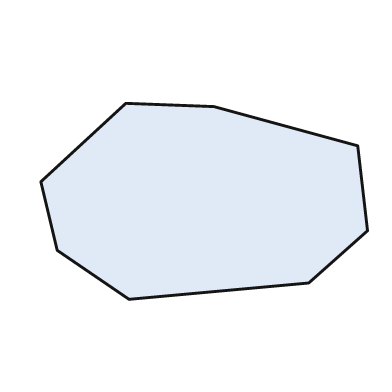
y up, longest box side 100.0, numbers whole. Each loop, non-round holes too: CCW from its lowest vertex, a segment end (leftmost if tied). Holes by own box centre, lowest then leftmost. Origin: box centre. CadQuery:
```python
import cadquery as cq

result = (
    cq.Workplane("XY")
    .moveTo(-23.0, -30.0)
    .lineTo(32.0, -25.0)
    .lineTo(50.0, -9.0)
    .lineTo(47.0, 17.0)
    .lineTo(3.0, 29.0)
    .lineTo(-24.0, 30.0)
    .lineTo(-50.0, 6.0)
    .lineTo(-45.0, -15.0)
    .close()
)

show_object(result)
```